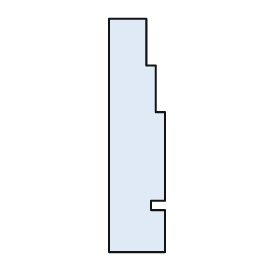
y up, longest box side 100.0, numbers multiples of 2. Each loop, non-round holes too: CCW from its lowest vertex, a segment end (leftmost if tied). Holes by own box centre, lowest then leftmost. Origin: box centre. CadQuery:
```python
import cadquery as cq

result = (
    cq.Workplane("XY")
    .moveTo(-12.0, -50.0)
    .lineTo(12.0, -50.0)
    .lineTo(12.0, -32.0)
    .lineTo(6.0, -32.0)
    .lineTo(6.0, -28.0)
    .lineTo(12.0, -28.0)
    .lineTo(12.0, 10.0)
    .lineTo(8.0, 10.0)
    .lineTo(8.0, 30.0)
    .lineTo(4.0, 30.0)
    .lineTo(4.0, 50.0)
    .lineTo(-12.0, 50.0)
    .close()
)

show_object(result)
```